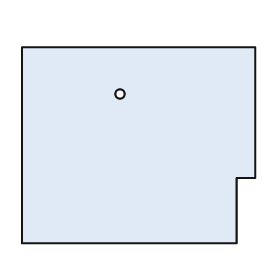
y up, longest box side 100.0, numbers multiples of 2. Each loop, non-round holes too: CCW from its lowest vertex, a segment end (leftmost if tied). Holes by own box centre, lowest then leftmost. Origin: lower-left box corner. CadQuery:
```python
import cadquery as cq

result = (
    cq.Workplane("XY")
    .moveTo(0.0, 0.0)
    .lineTo(92.0, 0.0)
    .lineTo(92.0, 28.0)
    .lineTo(100.0, 28.0)
    .lineTo(100.0, 84.0)
    .lineTo(0.0, 84.0)
    .close()
    .moveTo(42.0, 64.0)
    .circle(2.0)
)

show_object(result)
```